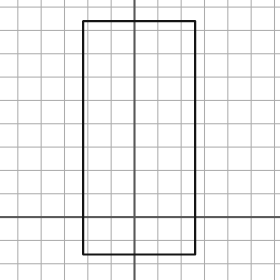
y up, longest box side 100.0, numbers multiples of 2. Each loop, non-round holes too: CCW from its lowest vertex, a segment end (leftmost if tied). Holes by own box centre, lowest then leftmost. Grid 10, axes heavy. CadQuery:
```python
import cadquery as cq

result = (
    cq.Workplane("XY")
    .moveTo(-22.0, -16.0)
    .lineTo(26.0, -16.0)
    .lineTo(26.0, 84.0)
    .lineTo(-22.0, 84.0)
    .close()
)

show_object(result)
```